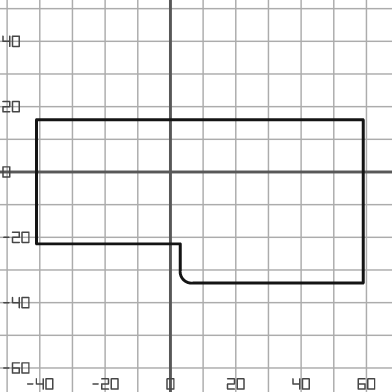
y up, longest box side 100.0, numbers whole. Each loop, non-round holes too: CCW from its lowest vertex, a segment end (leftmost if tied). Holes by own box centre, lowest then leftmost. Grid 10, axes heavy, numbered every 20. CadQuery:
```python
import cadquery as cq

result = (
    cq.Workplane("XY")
    .moveTo(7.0, -34.0)
    .lineTo(59.0, -34.0)
    .lineTo(59.0, 16.0)
    .lineTo(-41.0, 16.0)
    .lineTo(-41.0, -22.0)
    .lineTo(3.0, -22.0)
    .lineTo(3.0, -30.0)
    .threePointArc((4.0, -33.0), (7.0, -34.0))
    .close()
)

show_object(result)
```